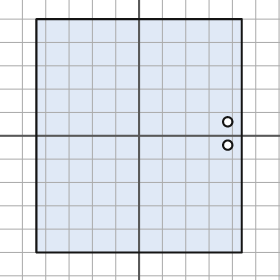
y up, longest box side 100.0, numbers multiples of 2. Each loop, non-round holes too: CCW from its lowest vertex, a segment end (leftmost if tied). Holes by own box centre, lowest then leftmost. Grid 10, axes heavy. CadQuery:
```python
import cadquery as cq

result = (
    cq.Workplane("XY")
    .moveTo(-44.0, -50.0)
    .lineTo(44.0, -50.0)
    .lineTo(44.0, 50.0)
    .lineTo(-44.0, 50.0)
    .close()
    .moveTo(38.0, -4.0)
    .circle(2.0)
    .moveTo(38.0, 6.0)
    .circle(2.0)
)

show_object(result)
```